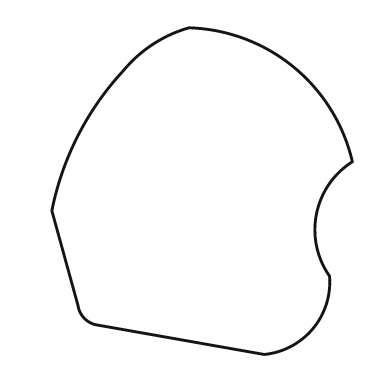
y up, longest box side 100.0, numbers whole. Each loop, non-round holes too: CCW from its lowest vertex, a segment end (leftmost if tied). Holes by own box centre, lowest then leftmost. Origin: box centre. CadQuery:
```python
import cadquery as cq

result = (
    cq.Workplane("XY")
    .moveTo(19.0, -50.0)
    .threePointArc((34.0, -42.0), (39.0, -26.0))
    .threePointArc((35.0, -7.0), (46.0, 9.0))
    .threePointArc((28.0, 38.0), (-4.0, 50.0))
    .threePointArc((-15.0, 45.0), (-24.0, 37.0))
    .threePointArc((-38.0, 17.0), (-46.0, -6.0))
    .lineTo(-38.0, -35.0)
    .threePointArc((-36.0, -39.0), (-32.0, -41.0))
    .close()
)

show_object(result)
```